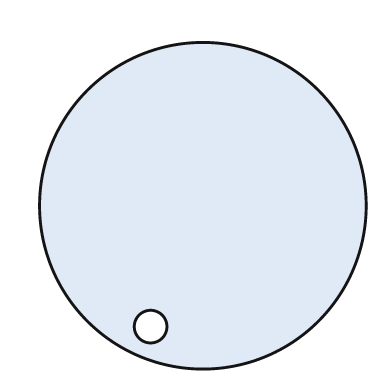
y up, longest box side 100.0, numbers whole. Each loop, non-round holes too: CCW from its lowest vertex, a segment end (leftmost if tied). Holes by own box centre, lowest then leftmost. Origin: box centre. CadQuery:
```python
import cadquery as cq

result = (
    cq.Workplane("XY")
    .moveTo(0.0, 0.0)
    .circle(50.0)
    .moveTo(-16.0, -37.0)
    .circle(5.0)
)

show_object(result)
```